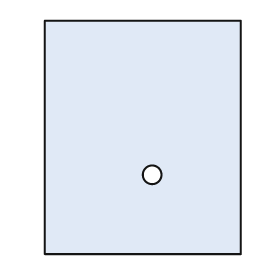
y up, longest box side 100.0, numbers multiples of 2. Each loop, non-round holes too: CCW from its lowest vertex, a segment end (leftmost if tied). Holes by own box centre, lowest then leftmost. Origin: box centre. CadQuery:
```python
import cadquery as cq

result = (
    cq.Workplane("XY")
    .moveTo(-42.0, -50.0)
    .lineTo(42.0, -50.0)
    .lineTo(42.0, 50.0)
    .lineTo(-42.0, 50.0)
    .close()
    .moveTo(4.0, -16.0)
    .circle(4.0)
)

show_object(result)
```